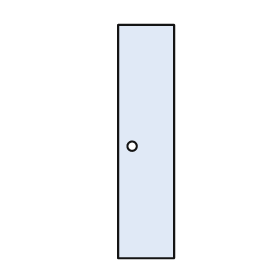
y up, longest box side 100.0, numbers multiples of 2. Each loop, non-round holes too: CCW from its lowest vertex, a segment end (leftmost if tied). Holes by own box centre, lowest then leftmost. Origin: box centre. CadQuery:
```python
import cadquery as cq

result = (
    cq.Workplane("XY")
    .moveTo(-12.0, -50.0)
    .lineTo(12.0, -50.0)
    .lineTo(12.0, 50.0)
    .lineTo(-12.0, 50.0)
    .close()
    .moveTo(-6.0, -2.0)
    .circle(2.0)
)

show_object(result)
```